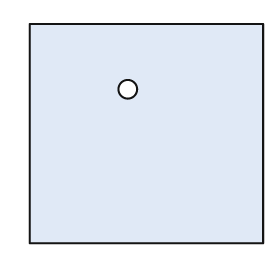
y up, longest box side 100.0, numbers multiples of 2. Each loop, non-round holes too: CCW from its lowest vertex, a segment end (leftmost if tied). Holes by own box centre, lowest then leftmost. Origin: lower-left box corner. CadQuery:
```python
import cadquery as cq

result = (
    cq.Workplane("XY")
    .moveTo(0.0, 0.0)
    .lineTo(100.0, 0.0)
    .lineTo(100.0, 94.0)
    .lineTo(0.0, 94.0)
    .close()
    .moveTo(42.0, 66.0)
    .circle(4.0)
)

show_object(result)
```